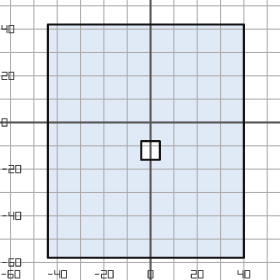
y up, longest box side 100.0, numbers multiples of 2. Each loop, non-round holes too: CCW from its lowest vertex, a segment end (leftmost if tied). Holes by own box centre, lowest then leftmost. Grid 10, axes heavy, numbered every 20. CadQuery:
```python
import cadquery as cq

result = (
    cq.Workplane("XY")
    .moveTo(-44.0, -58.0)
    .lineTo(40.0, -58.0)
    .lineTo(40.0, 42.0)
    .lineTo(-44.0, 42.0)
    .close()
    .moveTo(-4.0, -16.0)
    .lineTo(4.0, -16.0)
    .lineTo(4.0, -8.0)
    .lineTo(-4.0, -8.0)
    .close()
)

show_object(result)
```